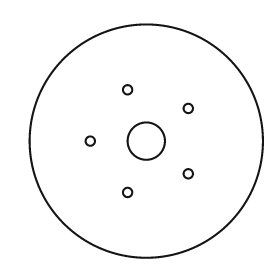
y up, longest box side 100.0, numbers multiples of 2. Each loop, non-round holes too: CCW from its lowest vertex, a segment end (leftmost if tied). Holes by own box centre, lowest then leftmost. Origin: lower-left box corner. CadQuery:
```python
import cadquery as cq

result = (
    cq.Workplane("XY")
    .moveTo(50.0, 50.0)
    .circle(50.0)
    .moveTo(42.0, 28.0)
    .circle(2.0)
    .moveTo(68.0, 36.0)
    .circle(2.0)
    .moveTo(26.0, 50.0)
    .circle(2.0)
    .moveTo(50.0, 50.0)
    .circle(8.0)
    .moveTo(68.0, 64.0)
    .circle(2.0)
    .moveTo(42.0, 72.0)
    .circle(2.0)
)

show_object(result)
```